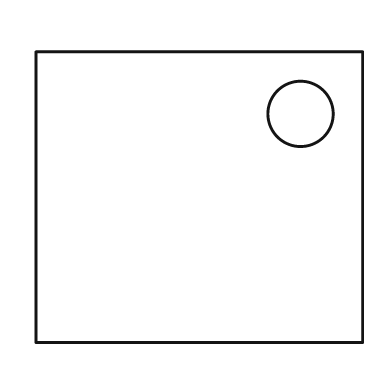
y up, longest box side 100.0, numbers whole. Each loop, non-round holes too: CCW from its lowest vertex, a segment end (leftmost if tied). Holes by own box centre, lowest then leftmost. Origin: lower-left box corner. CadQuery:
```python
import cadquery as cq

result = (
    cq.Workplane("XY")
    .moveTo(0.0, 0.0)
    .lineTo(100.0, 0.0)
    .lineTo(100.0, 89.0)
    .lineTo(0.0, 89.0)
    .close()
    .moveTo(81.0, 70.0)
    .circle(10.0)
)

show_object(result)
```